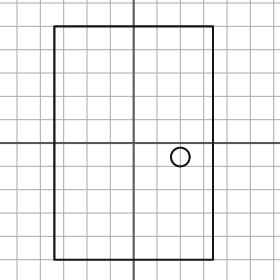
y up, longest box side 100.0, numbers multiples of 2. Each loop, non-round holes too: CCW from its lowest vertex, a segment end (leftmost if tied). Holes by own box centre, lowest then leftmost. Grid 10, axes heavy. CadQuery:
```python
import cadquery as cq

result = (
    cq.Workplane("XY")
    .moveTo(-34.0, -50.0)
    .lineTo(34.0, -50.0)
    .lineTo(34.0, 50.0)
    .lineTo(-34.0, 50.0)
    .close()
    .moveTo(20.0, -6.0)
    .circle(4.0)
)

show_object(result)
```